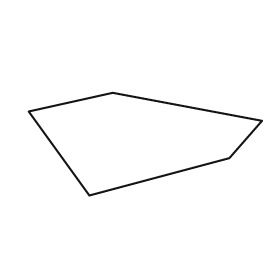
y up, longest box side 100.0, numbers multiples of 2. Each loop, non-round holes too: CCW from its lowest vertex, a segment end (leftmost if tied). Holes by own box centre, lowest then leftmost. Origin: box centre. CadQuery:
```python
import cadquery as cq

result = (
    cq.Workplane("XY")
    .moveTo(-24.0, -22.0)
    .lineTo(36.0, -6.0)
    .lineTo(50.0, 10.0)
    .lineTo(-14.0, 22.0)
    .lineTo(-50.0, 14.0)
    .close()
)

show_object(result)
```